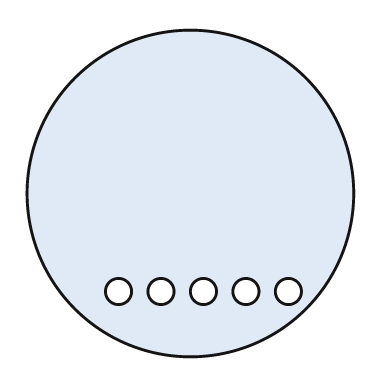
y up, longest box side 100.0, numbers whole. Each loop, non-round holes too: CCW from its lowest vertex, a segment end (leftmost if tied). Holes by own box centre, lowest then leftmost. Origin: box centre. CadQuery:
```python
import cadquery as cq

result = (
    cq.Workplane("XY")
    .moveTo(0.0, 0.0)
    .circle(50.0)
    .moveTo(-22.0, -30.0)
    .circle(4.0)
    .moveTo(-9.0, -30.0)
    .circle(4.0)
    .moveTo(4.0, -30.0)
    .circle(4.0)
    .moveTo(17.0, -30.0)
    .circle(4.0)
    .moveTo(30.0, -30.0)
    .circle(4.0)
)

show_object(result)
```